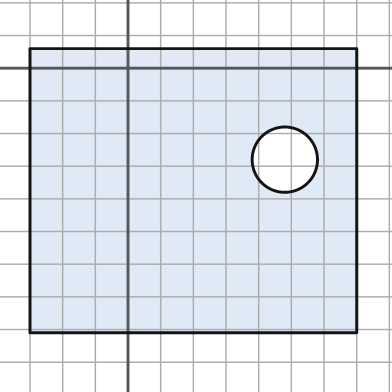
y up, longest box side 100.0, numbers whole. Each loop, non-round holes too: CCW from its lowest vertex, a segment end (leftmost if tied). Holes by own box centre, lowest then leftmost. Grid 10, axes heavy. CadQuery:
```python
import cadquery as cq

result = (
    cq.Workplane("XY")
    .moveTo(-30.0, -81.0)
    .lineTo(70.0, -81.0)
    .lineTo(70.0, 6.0)
    .lineTo(-30.0, 6.0)
    .close()
    .moveTo(48.0, -28.0)
    .circle(10.0)
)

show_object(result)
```